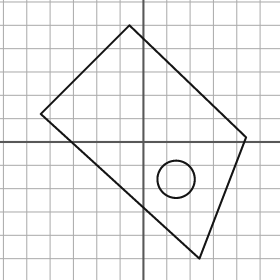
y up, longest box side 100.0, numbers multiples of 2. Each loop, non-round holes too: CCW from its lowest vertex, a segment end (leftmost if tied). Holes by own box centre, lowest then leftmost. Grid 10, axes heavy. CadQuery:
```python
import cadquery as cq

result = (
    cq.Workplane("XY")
    .moveTo(24.0, -50.0)
    .lineTo(44.0, 2.0)
    .lineTo(-6.0, 50.0)
    .lineTo(-44.0, 12.0)
    .close()
    .moveTo(14.0, -16.0)
    .circle(8.0)
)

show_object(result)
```